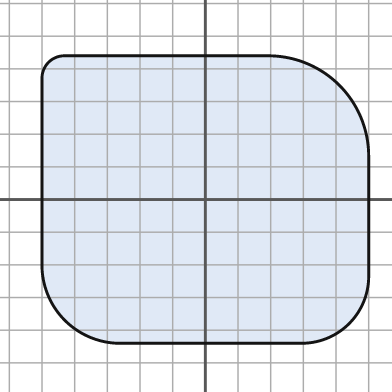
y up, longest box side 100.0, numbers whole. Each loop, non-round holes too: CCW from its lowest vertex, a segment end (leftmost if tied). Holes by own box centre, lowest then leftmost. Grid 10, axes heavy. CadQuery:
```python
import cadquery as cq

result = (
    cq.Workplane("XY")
    .moveTo(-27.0, -44.0)
    .lineTo(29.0, -44.0)
    .threePointArc((44.0, -38.0), (50.0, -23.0))
    .lineTo(50.0, 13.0)
    .threePointArc((41.0, 35.0), (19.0, 44.0))
    .lineTo(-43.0, 44.0)
    .threePointArc((-48.0, 42.0), (-50.0, 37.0))
    .lineTo(-50.0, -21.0)
    .threePointArc((-43.0, -37.0), (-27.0, -44.0))
    .close()
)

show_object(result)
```